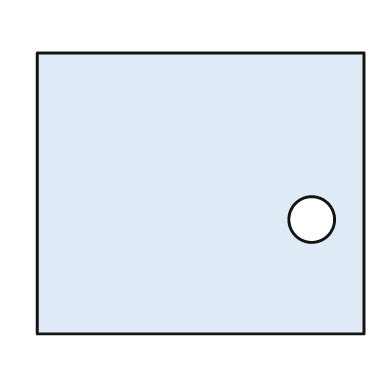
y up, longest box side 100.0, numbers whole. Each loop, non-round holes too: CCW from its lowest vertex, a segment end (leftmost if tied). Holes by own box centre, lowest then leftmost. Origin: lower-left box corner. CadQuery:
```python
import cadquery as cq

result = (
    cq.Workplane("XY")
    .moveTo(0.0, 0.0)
    .lineTo(100.0, 0.0)
    .lineTo(100.0, 86.0)
    .lineTo(0.0, 86.0)
    .close()
    .moveTo(84.0, 35.0)
    .circle(7.0)
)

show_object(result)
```